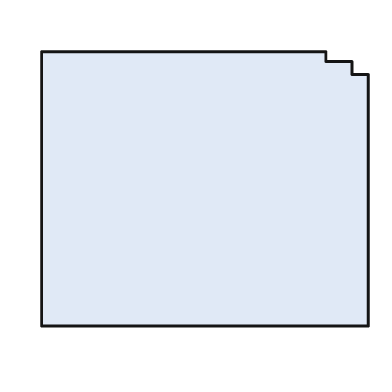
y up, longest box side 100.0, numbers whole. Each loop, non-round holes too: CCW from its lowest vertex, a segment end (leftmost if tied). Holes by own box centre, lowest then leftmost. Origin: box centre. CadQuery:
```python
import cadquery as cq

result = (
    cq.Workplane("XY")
    .moveTo(-50.0, -42.0)
    .lineTo(50.0, -42.0)
    .lineTo(50.0, 35.0)
    .lineTo(45.0, 35.0)
    .lineTo(45.0, 39.0)
    .lineTo(37.0, 39.0)
    .lineTo(37.0, 42.0)
    .lineTo(-50.0, 42.0)
    .close()
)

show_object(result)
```